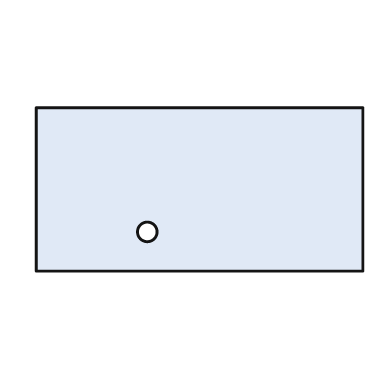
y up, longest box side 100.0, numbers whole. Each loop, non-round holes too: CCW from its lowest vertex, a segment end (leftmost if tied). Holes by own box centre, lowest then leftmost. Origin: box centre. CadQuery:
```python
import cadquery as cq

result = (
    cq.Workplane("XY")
    .moveTo(-50.0, -25.0)
    .lineTo(50.0, -25.0)
    .lineTo(50.0, 25.0)
    .lineTo(-50.0, 25.0)
    .close()
    .moveTo(-16.0, -13.0)
    .circle(3.0)
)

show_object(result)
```